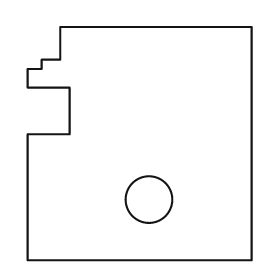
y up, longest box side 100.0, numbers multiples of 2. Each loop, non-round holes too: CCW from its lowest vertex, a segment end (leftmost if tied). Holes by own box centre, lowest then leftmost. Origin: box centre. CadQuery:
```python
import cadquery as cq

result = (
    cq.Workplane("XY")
    .moveTo(-48.0, -50.0)
    .lineTo(48.0, -50.0)
    .lineTo(48.0, 50.0)
    .lineTo(-34.0, 50.0)
    .lineTo(-34.0, 36.0)
    .lineTo(-42.0, 36.0)
    .lineTo(-42.0, 32.0)
    .lineTo(-48.0, 32.0)
    .lineTo(-48.0, 24.0)
    .lineTo(-30.0, 24.0)
    .lineTo(-30.0, 4.0)
    .lineTo(-48.0, 4.0)
    .close()
    .moveTo(4.0, -24.0)
    .circle(10.0)
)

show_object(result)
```